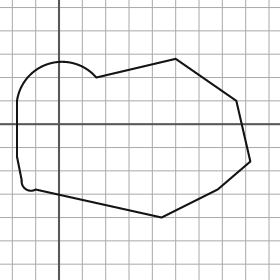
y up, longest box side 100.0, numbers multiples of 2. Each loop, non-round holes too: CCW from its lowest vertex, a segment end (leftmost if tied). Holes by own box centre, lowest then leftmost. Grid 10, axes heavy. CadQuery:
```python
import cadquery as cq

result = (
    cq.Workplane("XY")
    .moveTo(44.0, -40.0)
    .lineTo(68.0, -28.0)
    .lineTo(82.0, -16.0)
    .lineTo(76.0, 10.0)
    .lineTo(50.0, 28.0)
    .lineTo(16.0, 20.0)
    .threePointArc((-4.0, 26.0), (-18.0, 10.0))
    .lineTo(-18.0, -14.0)
    .lineTo(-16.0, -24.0)
    .threePointArc((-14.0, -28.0), (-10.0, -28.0))
    .close()
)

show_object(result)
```